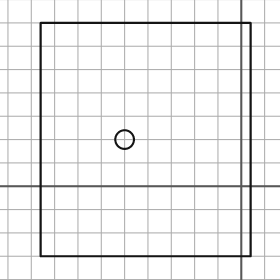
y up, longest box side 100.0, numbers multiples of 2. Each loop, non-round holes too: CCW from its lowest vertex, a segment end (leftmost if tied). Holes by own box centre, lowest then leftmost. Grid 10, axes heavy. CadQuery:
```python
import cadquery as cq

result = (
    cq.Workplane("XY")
    .moveTo(-86.0, -30.0)
    .lineTo(4.0, -30.0)
    .lineTo(4.0, 70.0)
    .lineTo(-86.0, 70.0)
    .close()
    .moveTo(-50.0, 20.0)
    .circle(4.0)
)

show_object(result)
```